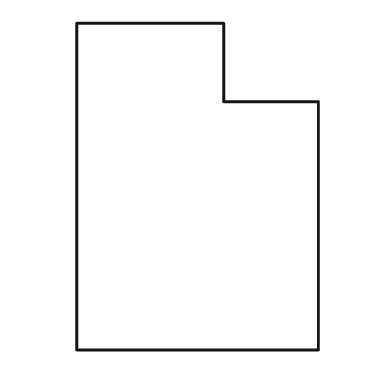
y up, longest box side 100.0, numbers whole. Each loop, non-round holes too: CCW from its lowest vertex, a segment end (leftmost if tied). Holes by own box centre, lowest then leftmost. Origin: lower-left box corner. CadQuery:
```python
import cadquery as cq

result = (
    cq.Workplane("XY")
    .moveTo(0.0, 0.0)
    .lineTo(74.0, 0.0)
    .lineTo(74.0, 76.0)
    .lineTo(45.0, 76.0)
    .lineTo(45.0, 100.0)
    .lineTo(0.0, 100.0)
    .close()
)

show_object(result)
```